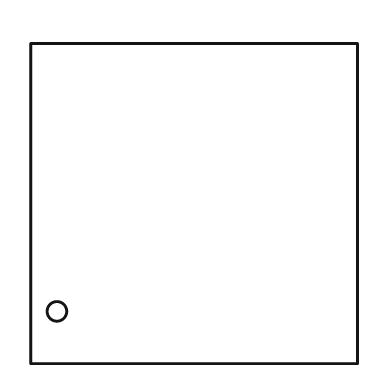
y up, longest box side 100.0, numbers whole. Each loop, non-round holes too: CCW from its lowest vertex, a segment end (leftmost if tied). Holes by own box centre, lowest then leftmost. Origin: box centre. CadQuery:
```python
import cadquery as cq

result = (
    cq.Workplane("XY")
    .moveTo(-50.0, -49.0)
    .lineTo(50.0, -49.0)
    .lineTo(50.0, 49.0)
    .lineTo(-50.0, 49.0)
    .close()
    .moveTo(-42.0, -33.0)
    .circle(3.0)
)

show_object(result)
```